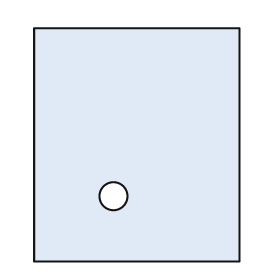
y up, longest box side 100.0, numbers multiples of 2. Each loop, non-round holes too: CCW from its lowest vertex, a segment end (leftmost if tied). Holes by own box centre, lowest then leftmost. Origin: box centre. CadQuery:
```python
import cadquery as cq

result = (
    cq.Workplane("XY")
    .moveTo(-44.0, -50.0)
    .lineTo(44.0, -50.0)
    .lineTo(44.0, 50.0)
    .lineTo(-44.0, 50.0)
    .close()
    .moveTo(-10.0, -22.0)
    .circle(6.0)
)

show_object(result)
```